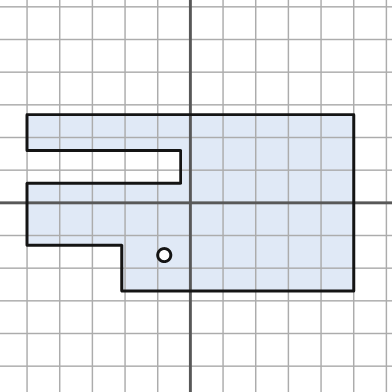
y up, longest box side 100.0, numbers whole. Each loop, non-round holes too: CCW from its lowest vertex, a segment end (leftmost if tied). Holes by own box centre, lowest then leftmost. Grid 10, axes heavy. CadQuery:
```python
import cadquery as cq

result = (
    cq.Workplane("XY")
    .moveTo(-21.0, -27.0)
    .lineTo(50.0, -27.0)
    .lineTo(50.0, 27.0)
    .lineTo(-50.0, 27.0)
    .lineTo(-50.0, 16.0)
    .lineTo(-3.0, 16.0)
    .lineTo(-3.0, 6.0)
    .lineTo(-50.0, 6.0)
    .lineTo(-50.0, -13.0)
    .lineTo(-21.0, -13.0)
    .close()
    .moveTo(-8.0, -16.0)
    .circle(2.0)
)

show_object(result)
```